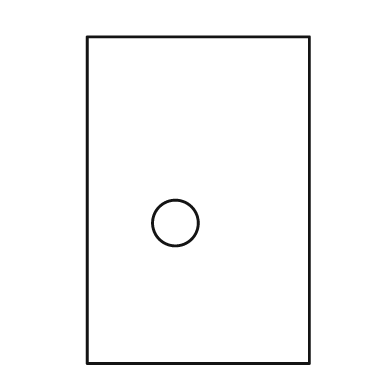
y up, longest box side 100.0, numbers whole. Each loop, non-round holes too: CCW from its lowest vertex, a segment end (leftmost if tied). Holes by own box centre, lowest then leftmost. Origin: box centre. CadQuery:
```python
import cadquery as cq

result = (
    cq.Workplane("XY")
    .moveTo(-34.0, -50.0)
    .lineTo(34.0, -50.0)
    .lineTo(34.0, 50.0)
    .lineTo(-34.0, 50.0)
    .close()
    .moveTo(-7.0, -7.0)
    .circle(7.0)
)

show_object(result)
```